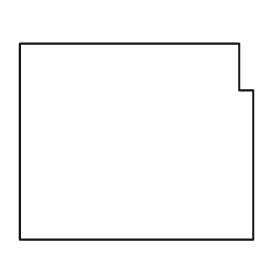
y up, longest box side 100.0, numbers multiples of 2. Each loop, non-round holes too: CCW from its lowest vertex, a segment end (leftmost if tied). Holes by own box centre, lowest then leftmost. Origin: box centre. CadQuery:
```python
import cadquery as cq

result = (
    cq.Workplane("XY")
    .moveTo(-50.0, -42.0)
    .lineTo(50.0, -42.0)
    .lineTo(50.0, 22.0)
    .lineTo(44.0, 22.0)
    .lineTo(44.0, 42.0)
    .lineTo(-50.0, 42.0)
    .close()
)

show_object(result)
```